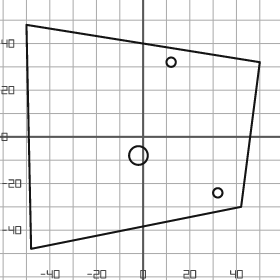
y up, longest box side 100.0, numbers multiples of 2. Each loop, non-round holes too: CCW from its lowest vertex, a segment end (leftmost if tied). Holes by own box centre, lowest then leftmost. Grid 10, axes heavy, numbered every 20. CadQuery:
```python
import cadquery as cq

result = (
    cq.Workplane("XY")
    .moveTo(-48.0, -48.0)
    .lineTo(42.0, -30.0)
    .lineTo(50.0, 32.0)
    .lineTo(-50.0, 48.0)
    .close()
    .moveTo(32.0, -24.0)
    .circle(2.0)
    .moveTo(-2.0, -8.0)
    .circle(4.0)
    .moveTo(12.0, 32.0)
    .circle(2.0)
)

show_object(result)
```